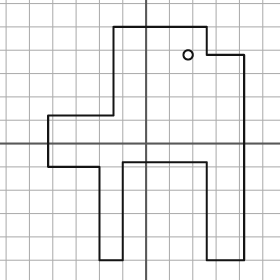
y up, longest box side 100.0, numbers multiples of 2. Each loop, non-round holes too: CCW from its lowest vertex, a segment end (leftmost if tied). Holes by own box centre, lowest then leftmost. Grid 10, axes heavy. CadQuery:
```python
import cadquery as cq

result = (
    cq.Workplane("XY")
    .moveTo(-20.0, -50.0)
    .lineTo(-10.0, -50.0)
    .lineTo(-10.0, -8.0)
    .lineTo(26.0, -8.0)
    .lineTo(26.0, -50.0)
    .lineTo(42.0, -50.0)
    .lineTo(42.0, 38.0)
    .lineTo(26.0, 38.0)
    .lineTo(26.0, 50.0)
    .lineTo(-14.0, 50.0)
    .lineTo(-14.0, 12.0)
    .lineTo(-42.0, 12.0)
    .lineTo(-42.0, -10.0)
    .lineTo(-20.0, -10.0)
    .close()
    .moveTo(18.0, 38.0)
    .circle(2.0)
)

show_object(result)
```